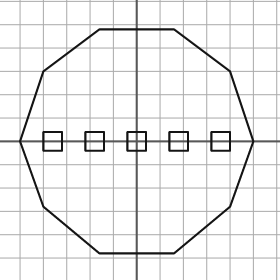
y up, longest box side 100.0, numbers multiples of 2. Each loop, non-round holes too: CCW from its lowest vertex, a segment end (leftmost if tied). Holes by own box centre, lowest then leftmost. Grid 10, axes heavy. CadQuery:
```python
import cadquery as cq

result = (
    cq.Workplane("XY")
    .moveTo(-16.0, -48.0)
    .lineTo(16.0, -48.0)
    .lineTo(40.0, -28.0)
    .lineTo(50.0, 0.0)
    .lineTo(40.0, 30.0)
    .lineTo(16.0, 48.0)
    .lineTo(-16.0, 48.0)
    .lineTo(-40.0, 30.0)
    .lineTo(-50.0, 0.0)
    .lineTo(-40.0, -28.0)
    .close()
    .moveTo(-40.0, -4.0)
    .lineTo(-32.0, -4.0)
    .lineTo(-32.0, 4.0)
    .lineTo(-40.0, 4.0)
    .close()
    .moveTo(-22.0, -4.0)
    .lineTo(-14.0, -4.0)
    .lineTo(-14.0, 4.0)
    .lineTo(-22.0, 4.0)
    .close()
    .moveTo(-4.0, -4.0)
    .lineTo(4.0, -4.0)
    .lineTo(4.0, 4.0)
    .lineTo(-4.0, 4.0)
    .close()
    .moveTo(14.0, -4.0)
    .lineTo(22.0, -4.0)
    .lineTo(22.0, 4.0)
    .lineTo(14.0, 4.0)
    .close()
    .moveTo(32.0, -4.0)
    .lineTo(40.0, -4.0)
    .lineTo(40.0, 4.0)
    .lineTo(32.0, 4.0)
    .close()
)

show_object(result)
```